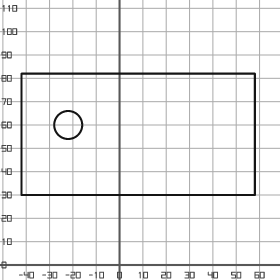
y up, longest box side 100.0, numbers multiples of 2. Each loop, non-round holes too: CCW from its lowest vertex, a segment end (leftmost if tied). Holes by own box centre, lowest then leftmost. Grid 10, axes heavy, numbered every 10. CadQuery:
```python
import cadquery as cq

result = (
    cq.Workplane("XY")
    .moveTo(-42.0, 30.0)
    .lineTo(58.0, 30.0)
    .lineTo(58.0, 82.0)
    .lineTo(-42.0, 82.0)
    .close()
    .moveTo(-22.0, 60.0)
    .circle(6.0)
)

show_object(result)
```